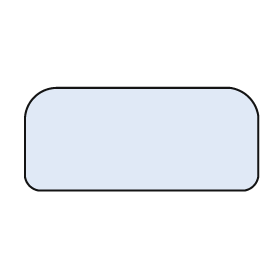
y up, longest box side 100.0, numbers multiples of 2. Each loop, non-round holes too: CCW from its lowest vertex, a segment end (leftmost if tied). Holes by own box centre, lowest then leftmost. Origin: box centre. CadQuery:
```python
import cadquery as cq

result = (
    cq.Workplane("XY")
    .moveTo(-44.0, -22.0)
    .lineTo(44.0, -22.0)
    .threePointArc((48.0, -20.0), (50.0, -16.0))
    .lineTo(50.0, 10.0)
    .threePointArc((46.0, 18.0), (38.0, 22.0))
    .lineTo(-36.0, 22.0)
    .threePointArc((-46.0, 18.0), (-50.0, 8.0))
    .lineTo(-50.0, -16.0)
    .threePointArc((-48.0, -20.0), (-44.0, -22.0))
    .close()
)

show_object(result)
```